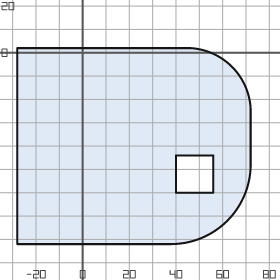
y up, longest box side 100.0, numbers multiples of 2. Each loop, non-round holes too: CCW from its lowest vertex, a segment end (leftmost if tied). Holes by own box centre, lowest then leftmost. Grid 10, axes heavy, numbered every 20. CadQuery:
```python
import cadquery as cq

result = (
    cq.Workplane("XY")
    .moveTo(-28.0, -82.0)
    .lineTo(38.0, -82.0)
    .threePointArc((62.0, -72.0), (72.0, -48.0))
    .lineTo(72.0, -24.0)
    .threePointArc((64.0, -6.0), (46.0, 2.0))
    .lineTo(-28.0, 2.0)
    .close()
    .moveTo(40.0, -60.0)
    .lineTo(56.0, -60.0)
    .lineTo(56.0, -44.0)
    .lineTo(40.0, -44.0)
    .close()
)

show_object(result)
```